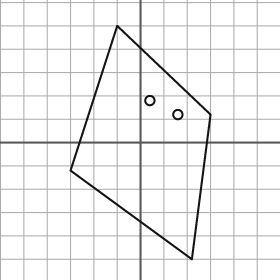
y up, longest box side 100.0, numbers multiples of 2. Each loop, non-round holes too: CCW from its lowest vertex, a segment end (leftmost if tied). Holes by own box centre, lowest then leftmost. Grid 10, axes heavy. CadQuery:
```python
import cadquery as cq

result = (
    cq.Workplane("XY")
    .moveTo(22.0, -50.0)
    .lineTo(30.0, 12.0)
    .lineTo(-10.0, 50.0)
    .lineTo(-30.0, -12.0)
    .close()
    .moveTo(16.0, 12.0)
    .circle(2.0)
    .moveTo(4.0, 18.0)
    .circle(2.0)
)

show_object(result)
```